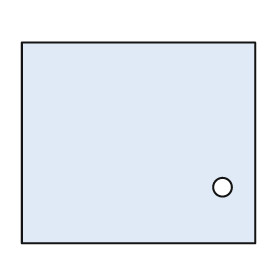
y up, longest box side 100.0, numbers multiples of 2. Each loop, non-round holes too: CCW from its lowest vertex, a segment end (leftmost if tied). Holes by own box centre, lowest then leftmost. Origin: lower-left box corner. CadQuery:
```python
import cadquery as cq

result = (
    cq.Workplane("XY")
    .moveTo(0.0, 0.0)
    .lineTo(100.0, 0.0)
    .lineTo(100.0, 86.0)
    .lineTo(0.0, 86.0)
    .close()
    .moveTo(86.0, 24.0)
    .circle(4.0)
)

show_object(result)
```